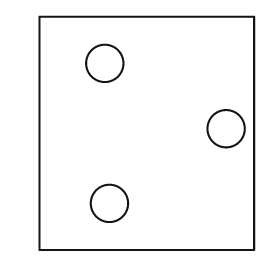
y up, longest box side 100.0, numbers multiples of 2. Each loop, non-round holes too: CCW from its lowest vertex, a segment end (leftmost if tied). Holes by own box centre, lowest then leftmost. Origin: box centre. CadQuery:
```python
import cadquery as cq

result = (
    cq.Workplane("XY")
    .moveTo(-46.0, -50.0)
    .lineTo(46.0, -50.0)
    .lineTo(46.0, 50.0)
    .lineTo(-46.0, 50.0)
    .close()
    .moveTo(-16.0, -30.0)
    .circle(8.0)
    .moveTo(34.0, 2.0)
    .circle(8.0)
    .moveTo(-18.0, 30.0)
    .circle(8.0)
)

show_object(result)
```